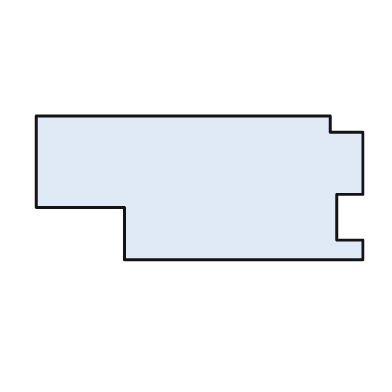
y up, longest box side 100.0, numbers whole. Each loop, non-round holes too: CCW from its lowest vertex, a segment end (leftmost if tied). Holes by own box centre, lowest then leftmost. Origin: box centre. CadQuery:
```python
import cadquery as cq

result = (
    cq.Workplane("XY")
    .moveTo(-23.0, -22.0)
    .lineTo(50.0, -22.0)
    .lineTo(50.0, -16.0)
    .lineTo(42.0, -16.0)
    .lineTo(42.0, -2.0)
    .lineTo(50.0, -2.0)
    .lineTo(50.0, 17.0)
    .lineTo(40.0, 17.0)
    .lineTo(40.0, 22.0)
    .lineTo(-50.0, 22.0)
    .lineTo(-50.0, -6.0)
    .lineTo(-23.0, -6.0)
    .close()
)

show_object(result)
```